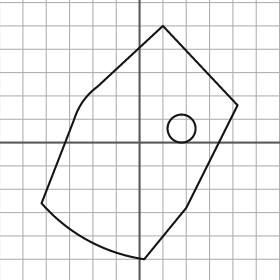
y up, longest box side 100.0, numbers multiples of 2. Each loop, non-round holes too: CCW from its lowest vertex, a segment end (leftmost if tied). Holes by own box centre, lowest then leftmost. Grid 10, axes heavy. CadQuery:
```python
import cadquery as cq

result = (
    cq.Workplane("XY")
    .moveTo(2.0, -50.0)
    .lineTo(20.0, -28.0)
    .lineTo(42.0, 16.0)
    .lineTo(10.0, 50.0)
    .lineTo(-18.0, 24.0)
    .threePointArc((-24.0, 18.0), (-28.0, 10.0))
    .lineTo(-42.0, -26.0)
    .threePointArc((-22.0, -42.0), (2.0, -50.0))
    .close()
    .moveTo(18.0, 6.0)
    .circle(6.0)
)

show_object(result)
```